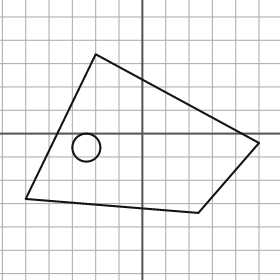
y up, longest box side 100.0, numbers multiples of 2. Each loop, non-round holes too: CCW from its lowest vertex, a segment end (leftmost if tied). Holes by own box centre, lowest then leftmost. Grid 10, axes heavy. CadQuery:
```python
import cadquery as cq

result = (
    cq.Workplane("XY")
    .moveTo(24.0, -34.0)
    .lineTo(50.0, -4.0)
    .lineTo(-20.0, 34.0)
    .lineTo(-50.0, -28.0)
    .close()
    .moveTo(-24.0, -6.0)
    .circle(6.0)
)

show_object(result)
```